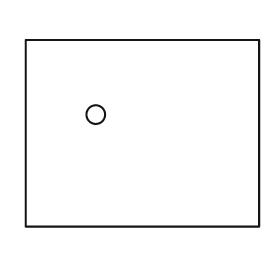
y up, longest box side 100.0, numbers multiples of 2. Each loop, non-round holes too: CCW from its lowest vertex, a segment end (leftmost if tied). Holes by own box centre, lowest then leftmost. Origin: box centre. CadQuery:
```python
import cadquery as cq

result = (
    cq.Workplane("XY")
    .moveTo(-50.0, -40.0)
    .lineTo(50.0, -40.0)
    .lineTo(50.0, 40.0)
    .lineTo(-50.0, 40.0)
    .close()
    .moveTo(-20.0, 8.0)
    .circle(4.0)
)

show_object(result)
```